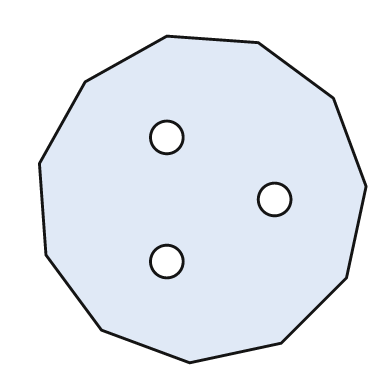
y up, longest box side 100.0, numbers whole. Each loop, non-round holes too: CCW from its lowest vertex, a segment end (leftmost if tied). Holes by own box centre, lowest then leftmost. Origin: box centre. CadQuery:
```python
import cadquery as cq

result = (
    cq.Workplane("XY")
    .moveTo(-4.0, -50.0)
    .lineTo(24.0, -44.0)
    .lineTo(44.0, -24.0)
    .lineTo(50.0, 4.0)
    .lineTo(40.0, 31.0)
    .lineTo(17.0, 48.0)
    .lineTo(-11.0, 50.0)
    .lineTo(-36.0, 36.0)
    .lineTo(-50.0, 11.0)
    .lineTo(-48.0, -17.0)
    .lineTo(-31.0, -40.0)
    .close()
    .moveTo(-11.0, -19.0)
    .circle(5.0)
    .moveTo(22.0, 0.0)
    .circle(5.0)
    .moveTo(-11.0, 19.0)
    .circle(5.0)
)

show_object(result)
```